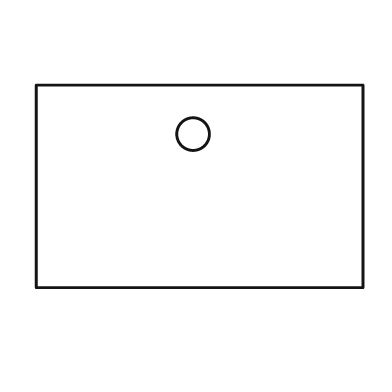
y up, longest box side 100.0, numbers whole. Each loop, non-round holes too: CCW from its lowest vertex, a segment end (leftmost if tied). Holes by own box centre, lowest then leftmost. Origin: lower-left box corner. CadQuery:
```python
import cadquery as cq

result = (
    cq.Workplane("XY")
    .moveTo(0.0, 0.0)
    .lineTo(100.0, 0.0)
    .lineTo(100.0, 62.0)
    .lineTo(0.0, 62.0)
    .close()
    .moveTo(48.0, 47.0)
    .circle(5.0)
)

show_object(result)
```